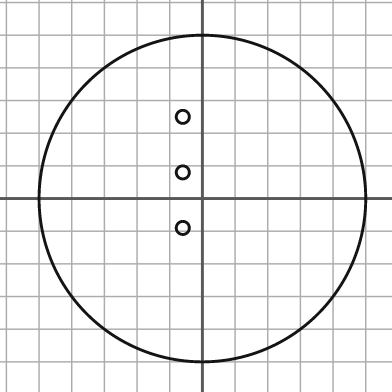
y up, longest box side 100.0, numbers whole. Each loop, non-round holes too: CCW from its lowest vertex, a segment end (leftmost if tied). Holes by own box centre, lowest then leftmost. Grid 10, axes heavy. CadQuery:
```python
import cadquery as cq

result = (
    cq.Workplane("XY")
    .moveTo(0.0, 0.0)
    .circle(50.0)
    .moveTo(-6.0, -9.0)
    .circle(2.0)
    .moveTo(-6.0, 8.0)
    .circle(2.0)
    .moveTo(-6.0, 25.0)
    .circle(2.0)
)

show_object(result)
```